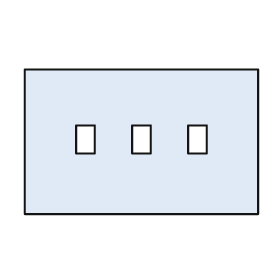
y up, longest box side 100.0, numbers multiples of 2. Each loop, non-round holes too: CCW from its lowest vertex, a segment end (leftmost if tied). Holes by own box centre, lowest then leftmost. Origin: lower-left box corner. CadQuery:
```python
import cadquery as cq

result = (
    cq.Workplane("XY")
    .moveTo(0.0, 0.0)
    .lineTo(100.0, 0.0)
    .lineTo(100.0, 62.0)
    .lineTo(0.0, 62.0)
    .close()
    .moveTo(22.0, 26.0)
    .lineTo(30.0, 26.0)
    .lineTo(30.0, 38.0)
    .lineTo(22.0, 38.0)
    .close()
    .moveTo(46.0, 26.0)
    .lineTo(54.0, 26.0)
    .lineTo(54.0, 38.0)
    .lineTo(46.0, 38.0)
    .close()
    .moveTo(70.0, 26.0)
    .lineTo(78.0, 26.0)
    .lineTo(78.0, 38.0)
    .lineTo(70.0, 38.0)
    .close()
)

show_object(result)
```